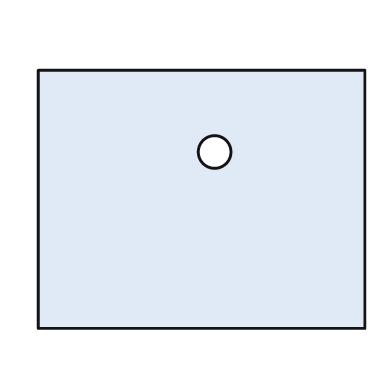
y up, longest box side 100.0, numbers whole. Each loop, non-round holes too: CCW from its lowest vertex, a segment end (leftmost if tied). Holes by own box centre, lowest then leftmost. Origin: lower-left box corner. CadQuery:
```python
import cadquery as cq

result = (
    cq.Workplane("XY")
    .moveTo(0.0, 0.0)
    .lineTo(100.0, 0.0)
    .lineTo(100.0, 79.0)
    .lineTo(0.0, 79.0)
    .close()
    .moveTo(54.0, 54.0)
    .circle(5.0)
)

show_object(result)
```